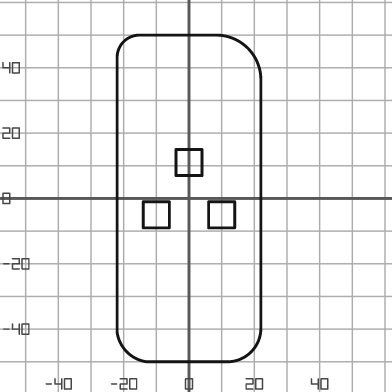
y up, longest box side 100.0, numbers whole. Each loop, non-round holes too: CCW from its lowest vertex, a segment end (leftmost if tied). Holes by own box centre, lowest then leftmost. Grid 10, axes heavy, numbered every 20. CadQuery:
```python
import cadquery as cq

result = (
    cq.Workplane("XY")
    .moveTo(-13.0, -50.0)
    .lineTo(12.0, -50.0)
    .threePointArc((19.0, -47.0), (22.0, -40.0))
    .lineTo(22.0, 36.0)
    .threePointArc((18.0, 46.0), (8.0, 50.0))
    .lineTo(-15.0, 50.0)
    .threePointArc((-20.0, 48.0), (-22.0, 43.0))
    .lineTo(-22.0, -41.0)
    .threePointArc((-19.0, -47.0), (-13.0, -50.0))
    .close()
    .moveTo(-14.0, -9.0)
    .lineTo(-6.0, -9.0)
    .lineTo(-6.0, -1.0)
    .lineTo(-14.0, -1.0)
    .close()
    .moveTo(6.0, -9.0)
    .lineTo(14.0, -9.0)
    .lineTo(14.0, -1.0)
    .lineTo(6.0, -1.0)
    .close()
    .moveTo(-4.0, 7.0)
    .lineTo(4.0, 7.0)
    .lineTo(4.0, 15.0)
    .lineTo(-4.0, 15.0)
    .close()
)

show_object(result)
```